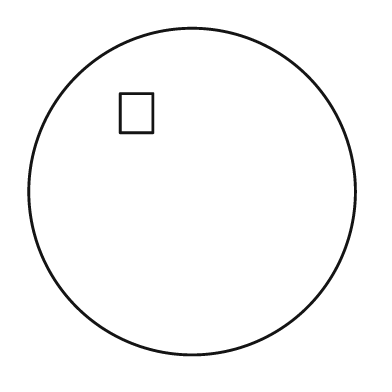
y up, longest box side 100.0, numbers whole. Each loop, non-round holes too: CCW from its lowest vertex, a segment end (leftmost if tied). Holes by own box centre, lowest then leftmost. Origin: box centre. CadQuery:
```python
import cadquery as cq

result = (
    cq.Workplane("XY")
    .moveTo(0.0, 0.0)
    .circle(50.0)
    .moveTo(-22.0, 18.0)
    .lineTo(-12.0, 18.0)
    .lineTo(-12.0, 30.0)
    .lineTo(-22.0, 30.0)
    .close()
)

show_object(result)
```